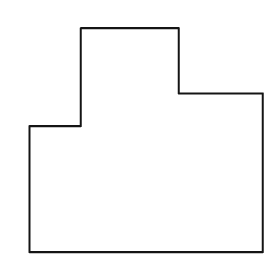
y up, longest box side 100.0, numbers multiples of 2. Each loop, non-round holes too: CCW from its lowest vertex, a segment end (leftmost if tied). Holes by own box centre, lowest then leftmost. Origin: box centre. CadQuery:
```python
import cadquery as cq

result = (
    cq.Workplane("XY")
    .moveTo(-50.0, -48.0)
    .lineTo(50.0, -48.0)
    .lineTo(50.0, 20.0)
    .lineTo(14.0, 20.0)
    .lineTo(14.0, 48.0)
    .lineTo(-28.0, 48.0)
    .lineTo(-28.0, 6.0)
    .lineTo(-50.0, 6.0)
    .close()
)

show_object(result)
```